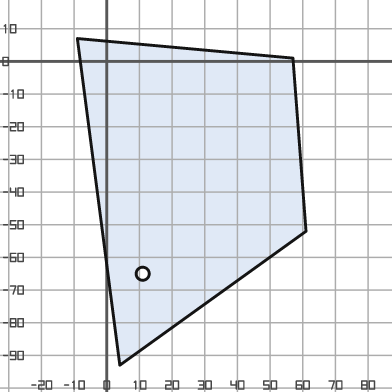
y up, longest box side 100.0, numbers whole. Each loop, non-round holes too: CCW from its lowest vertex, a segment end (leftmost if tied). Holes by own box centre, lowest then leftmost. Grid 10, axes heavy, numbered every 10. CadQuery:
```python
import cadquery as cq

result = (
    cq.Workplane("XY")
    .moveTo(4.0, -93.0)
    .lineTo(61.0, -52.0)
    .lineTo(57.0, 1.0)
    .lineTo(-9.0, 7.0)
    .close()
    .moveTo(11.0, -65.0)
    .circle(2.0)
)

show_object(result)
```